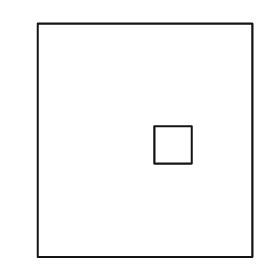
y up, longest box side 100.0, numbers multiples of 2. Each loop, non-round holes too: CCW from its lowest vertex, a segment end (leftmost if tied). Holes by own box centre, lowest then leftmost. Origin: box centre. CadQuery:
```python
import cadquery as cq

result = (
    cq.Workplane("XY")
    .moveTo(-46.0, -50.0)
    .lineTo(46.0, -50.0)
    .lineTo(46.0, 50.0)
    .lineTo(-46.0, 50.0)
    .close()
    .moveTo(4.0, -10.0)
    .lineTo(20.0, -10.0)
    .lineTo(20.0, 6.0)
    .lineTo(4.0, 6.0)
    .close()
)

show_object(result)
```